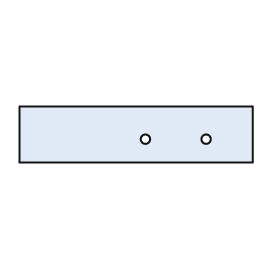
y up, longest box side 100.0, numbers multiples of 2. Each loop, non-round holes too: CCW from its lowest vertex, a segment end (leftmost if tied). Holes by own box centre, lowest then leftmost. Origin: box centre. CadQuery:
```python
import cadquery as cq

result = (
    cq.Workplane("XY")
    .moveTo(-50.0, -12.0)
    .lineTo(50.0, -12.0)
    .lineTo(50.0, 12.0)
    .lineTo(-50.0, 12.0)
    .close()
    .moveTo(4.0, -2.0)
    .circle(2.0)
    .moveTo(30.0, -2.0)
    .circle(2.0)
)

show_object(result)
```